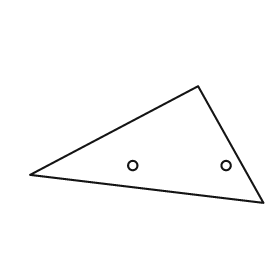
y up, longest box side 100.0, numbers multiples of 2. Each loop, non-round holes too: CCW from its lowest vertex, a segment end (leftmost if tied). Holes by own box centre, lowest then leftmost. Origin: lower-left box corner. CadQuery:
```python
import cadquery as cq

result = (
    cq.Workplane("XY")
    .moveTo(100.0, 0.0)
    .lineTo(72.0, 50.0)
    .lineTo(0.0, 12.0)
    .close()
    .moveTo(44.0, 16.0)
    .circle(2.0)
    .moveTo(84.0, 16.0)
    .circle(2.0)
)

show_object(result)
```